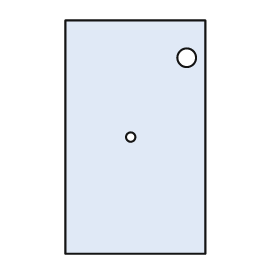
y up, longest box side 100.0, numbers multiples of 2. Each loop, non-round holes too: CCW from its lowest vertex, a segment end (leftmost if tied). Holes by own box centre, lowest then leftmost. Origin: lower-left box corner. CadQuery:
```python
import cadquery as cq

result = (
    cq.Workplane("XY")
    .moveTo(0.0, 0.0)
    .lineTo(60.0, 0.0)
    .lineTo(60.0, 100.0)
    .lineTo(0.0, 100.0)
    .close()
    .moveTo(28.0, 50.0)
    .circle(2.0)
    .moveTo(52.0, 84.0)
    .circle(4.0)
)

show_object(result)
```